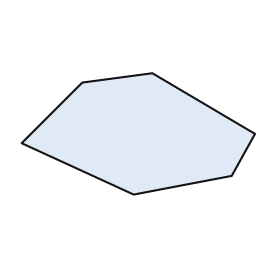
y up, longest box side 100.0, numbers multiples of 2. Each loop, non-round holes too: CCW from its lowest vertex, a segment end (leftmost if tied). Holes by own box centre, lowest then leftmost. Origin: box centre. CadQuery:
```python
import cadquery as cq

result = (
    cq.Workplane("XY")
    .moveTo(-2.0, -26.0)
    .lineTo(40.0, -18.0)
    .lineTo(50.0, 0.0)
    .lineTo(6.0, 26.0)
    .lineTo(-24.0, 22.0)
    .lineTo(-50.0, -4.0)
    .close()
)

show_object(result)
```